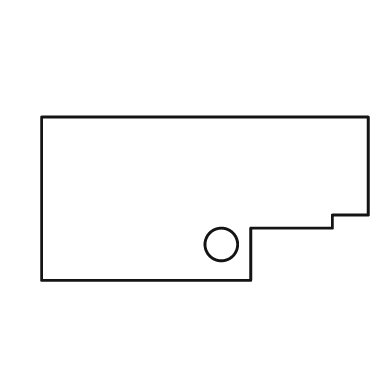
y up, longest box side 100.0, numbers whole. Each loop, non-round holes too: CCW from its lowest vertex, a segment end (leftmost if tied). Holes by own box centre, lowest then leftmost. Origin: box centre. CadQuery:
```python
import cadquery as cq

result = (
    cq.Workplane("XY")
    .moveTo(-50.0, -25.0)
    .lineTo(14.0, -25.0)
    .lineTo(14.0, -9.0)
    .lineTo(39.0, -9.0)
    .lineTo(39.0, -5.0)
    .lineTo(50.0, -5.0)
    .lineTo(50.0, 25.0)
    .lineTo(-50.0, 25.0)
    .close()
    .moveTo(5.0, -14.0)
    .circle(5.0)
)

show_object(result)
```